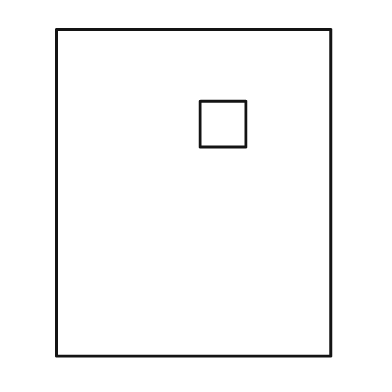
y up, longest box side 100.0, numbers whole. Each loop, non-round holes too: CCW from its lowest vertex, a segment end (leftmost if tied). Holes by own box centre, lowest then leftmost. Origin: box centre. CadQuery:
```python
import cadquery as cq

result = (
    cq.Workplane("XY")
    .moveTo(-42.0, -50.0)
    .lineTo(42.0, -50.0)
    .lineTo(42.0, 50.0)
    .lineTo(-42.0, 50.0)
    .close()
    .moveTo(2.0, 14.0)
    .lineTo(16.0, 14.0)
    .lineTo(16.0, 28.0)
    .lineTo(2.0, 28.0)
    .close()
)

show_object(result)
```